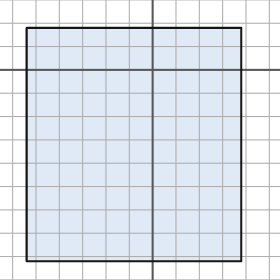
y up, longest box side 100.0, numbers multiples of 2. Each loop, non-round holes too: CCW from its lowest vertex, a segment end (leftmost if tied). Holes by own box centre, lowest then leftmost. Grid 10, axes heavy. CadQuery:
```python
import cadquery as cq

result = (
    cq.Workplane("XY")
    .moveTo(-54.0, -82.0)
    .lineTo(38.0, -82.0)
    .lineTo(38.0, 18.0)
    .lineTo(-54.0, 18.0)
    .close()
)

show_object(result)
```